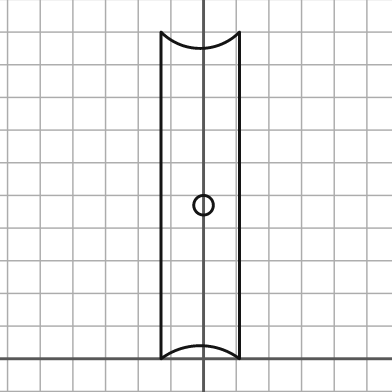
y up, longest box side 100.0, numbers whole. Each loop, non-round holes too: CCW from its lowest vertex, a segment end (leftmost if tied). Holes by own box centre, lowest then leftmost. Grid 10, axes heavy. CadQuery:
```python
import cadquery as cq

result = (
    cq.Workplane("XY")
    .moveTo(-13.0, 0.0)
    .threePointArc((-1.0, 4.0), (11.0, 0.0))
    .lineTo(11.0, 100.0)
    .threePointArc((-1.0, 95.0), (-13.0, 100.0))
    .close()
    .moveTo(0.0, 47.0)
    .circle(3.0)
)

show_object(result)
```